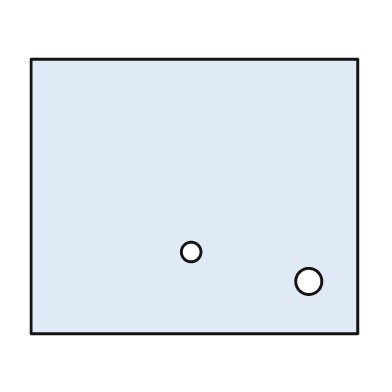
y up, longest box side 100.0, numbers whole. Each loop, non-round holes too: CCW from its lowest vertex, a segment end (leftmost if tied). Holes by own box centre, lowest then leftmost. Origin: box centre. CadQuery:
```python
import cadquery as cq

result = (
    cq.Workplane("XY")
    .moveTo(-50.0, -42.0)
    .lineTo(50.0, -42.0)
    .lineTo(50.0, 42.0)
    .lineTo(-50.0, 42.0)
    .close()
    .moveTo(35.0, -26.0)
    .circle(4.0)
    .moveTo(-1.0, -17.0)
    .circle(3.0)
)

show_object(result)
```